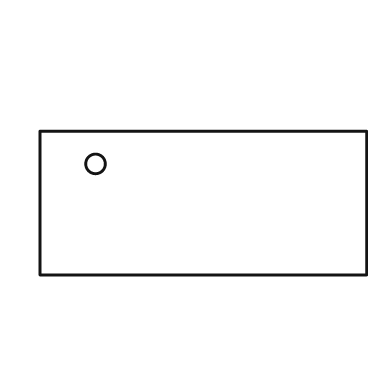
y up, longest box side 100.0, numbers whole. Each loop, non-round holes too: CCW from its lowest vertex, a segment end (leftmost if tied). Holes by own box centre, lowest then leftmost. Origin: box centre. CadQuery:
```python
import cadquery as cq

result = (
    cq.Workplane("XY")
    .moveTo(-50.0, -22.0)
    .lineTo(50.0, -22.0)
    .lineTo(50.0, 22.0)
    .lineTo(-50.0, 22.0)
    .close()
    .moveTo(-33.0, 12.0)
    .circle(3.0)
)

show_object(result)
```